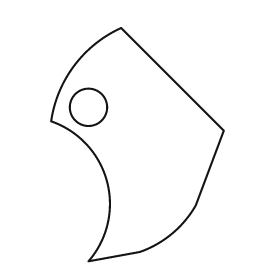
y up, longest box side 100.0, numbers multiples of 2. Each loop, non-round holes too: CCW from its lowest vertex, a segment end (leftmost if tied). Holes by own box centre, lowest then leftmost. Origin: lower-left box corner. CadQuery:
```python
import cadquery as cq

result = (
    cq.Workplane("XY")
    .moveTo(16.0, 0.0)
    .lineTo(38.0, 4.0)
    .threePointArc((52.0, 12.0), (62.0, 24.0))
    .lineTo(74.0, 56.0)
    .lineTo(30.0, 100.0)
    .threePointArc((10.0, 84.0), (0.0, 60.0))
    .threePointArc((24.0, 34.0), (16.0, 0.0))
    .close()
    .moveTo(16.0, 66.0)
    .circle(8.0)
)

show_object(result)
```